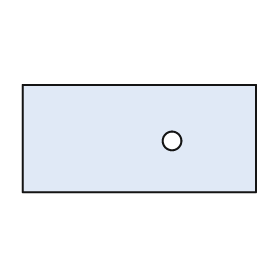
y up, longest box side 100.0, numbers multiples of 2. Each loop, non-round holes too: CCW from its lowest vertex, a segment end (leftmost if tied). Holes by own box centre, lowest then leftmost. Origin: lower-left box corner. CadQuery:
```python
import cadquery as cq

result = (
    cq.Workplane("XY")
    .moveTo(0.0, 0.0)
    .lineTo(100.0, 0.0)
    .lineTo(100.0, 46.0)
    .lineTo(0.0, 46.0)
    .close()
    .moveTo(64.0, 22.0)
    .circle(4.0)
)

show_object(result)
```